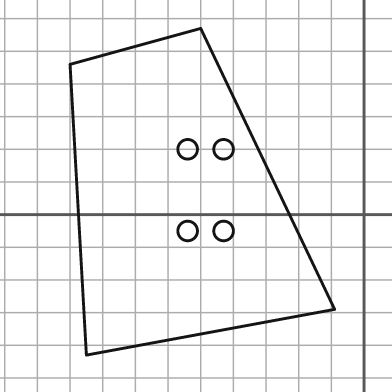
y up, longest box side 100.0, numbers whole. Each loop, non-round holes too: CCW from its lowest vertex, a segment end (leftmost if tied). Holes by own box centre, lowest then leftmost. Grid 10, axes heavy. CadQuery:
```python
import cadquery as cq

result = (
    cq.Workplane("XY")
    .moveTo(-85.0, -43.0)
    .lineTo(-9.0, -29.0)
    .lineTo(-50.0, 57.0)
    .lineTo(-90.0, 46.0)
    .close()
    .moveTo(-54.0, -5.0)
    .circle(3.0)
    .moveTo(-43.0, -5.0)
    .circle(3.0)
    .moveTo(-54.0, 20.0)
    .circle(3.0)
    .moveTo(-43.0, 20.0)
    .circle(3.0)
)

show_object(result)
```